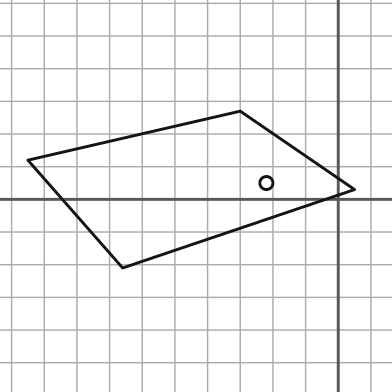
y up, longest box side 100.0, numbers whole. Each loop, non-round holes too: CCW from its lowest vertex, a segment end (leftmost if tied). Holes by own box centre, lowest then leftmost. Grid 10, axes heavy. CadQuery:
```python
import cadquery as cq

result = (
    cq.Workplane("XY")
    .moveTo(-66.0, -21.0)
    .lineTo(5.0, 3.0)
    .lineTo(-30.0, 27.0)
    .lineTo(-95.0, 12.0)
    .close()
    .moveTo(-22.0, 5.0)
    .circle(2.0)
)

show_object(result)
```